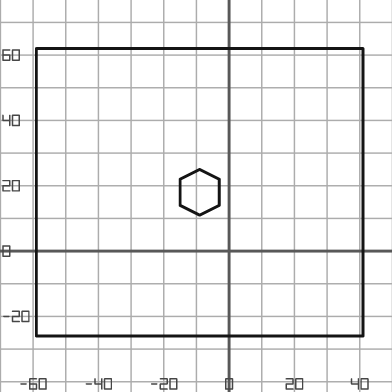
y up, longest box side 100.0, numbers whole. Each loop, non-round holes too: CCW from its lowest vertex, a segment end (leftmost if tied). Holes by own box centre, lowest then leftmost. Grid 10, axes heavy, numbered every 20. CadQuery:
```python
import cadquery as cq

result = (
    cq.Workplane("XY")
    .moveTo(-59.0, -26.0)
    .lineTo(41.0, -26.0)
    .lineTo(41.0, 62.0)
    .lineTo(-59.0, 62.0)
    .close()
    .moveTo(-9.0, 11.0)
    .lineTo(-3.0, 14.0)
    .lineTo(-3.0, 22.0)
    .lineTo(-9.0, 25.0)
    .lineTo(-15.0, 22.0)
    .lineTo(-15.0, 14.0)
    .close()
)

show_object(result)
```